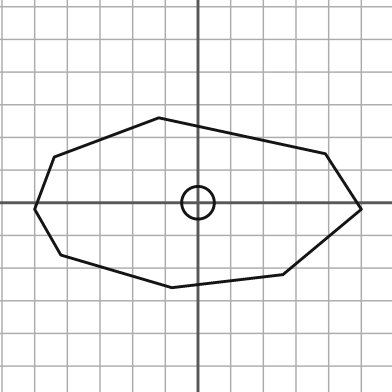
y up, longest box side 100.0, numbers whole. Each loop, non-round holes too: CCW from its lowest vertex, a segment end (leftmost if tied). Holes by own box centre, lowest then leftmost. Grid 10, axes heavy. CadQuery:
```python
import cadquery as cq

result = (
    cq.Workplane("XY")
    .moveTo(-8.0, -26.0)
    .lineTo(26.0, -22.0)
    .lineTo(50.0, -2.0)
    .lineTo(39.0, 15.0)
    .lineTo(-12.0, 26.0)
    .lineTo(-44.0, 14.0)
    .lineTo(-50.0, -2.0)
    .lineTo(-42.0, -16.0)
    .close()
    .moveTo(0.0, 0.0)
    .circle(5.0)
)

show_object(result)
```